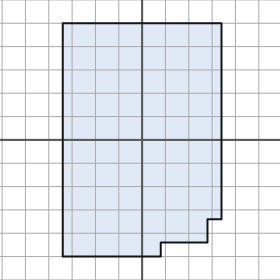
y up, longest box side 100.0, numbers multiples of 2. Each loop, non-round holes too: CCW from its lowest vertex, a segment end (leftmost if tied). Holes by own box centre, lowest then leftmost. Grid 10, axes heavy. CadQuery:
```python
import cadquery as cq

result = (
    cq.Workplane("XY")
    .moveTo(-34.0, -50.0)
    .lineTo(8.0, -50.0)
    .lineTo(8.0, -44.0)
    .lineTo(28.0, -44.0)
    .lineTo(28.0, -34.0)
    .lineTo(34.0, -34.0)
    .lineTo(34.0, 50.0)
    .lineTo(-34.0, 50.0)
    .close()
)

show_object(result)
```